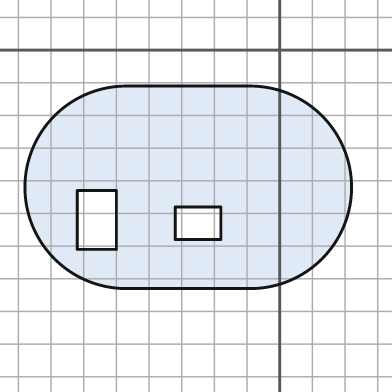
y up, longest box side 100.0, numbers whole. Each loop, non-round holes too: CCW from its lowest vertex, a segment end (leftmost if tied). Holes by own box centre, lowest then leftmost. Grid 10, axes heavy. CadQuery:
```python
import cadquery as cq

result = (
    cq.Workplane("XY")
    .moveTo(-47.0, -73.0)
    .lineTo(-9.0, -73.0)
    .threePointArc((22.0, -42.0), (-9.0, -11.0))
    .lineTo(-47.0, -11.0)
    .threePointArc((-78.0, -42.0), (-47.0, -73.0))
    .close()
    .moveTo(-32.0, -58.0)
    .lineTo(-18.0, -58.0)
    .lineTo(-18.0, -48.0)
    .lineTo(-32.0, -48.0)
    .close()
    .moveTo(-62.0, -61.0)
    .lineTo(-50.0, -61.0)
    .lineTo(-50.0, -43.0)
    .lineTo(-62.0, -43.0)
    .close()
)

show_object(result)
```